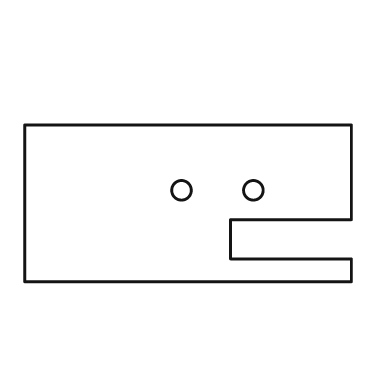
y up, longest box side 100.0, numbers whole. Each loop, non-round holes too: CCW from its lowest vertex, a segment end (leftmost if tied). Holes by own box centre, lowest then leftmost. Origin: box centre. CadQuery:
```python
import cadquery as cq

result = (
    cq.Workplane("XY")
    .moveTo(-50.0, -24.0)
    .lineTo(50.0, -24.0)
    .lineTo(50.0, -17.0)
    .lineTo(13.0, -17.0)
    .lineTo(13.0, -5.0)
    .lineTo(50.0, -5.0)
    .lineTo(50.0, 24.0)
    .lineTo(-50.0, 24.0)
    .close()
    .moveTo(-2.0, 4.0)
    .circle(3.0)
    .moveTo(20.0, 4.0)
    .circle(3.0)
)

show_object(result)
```